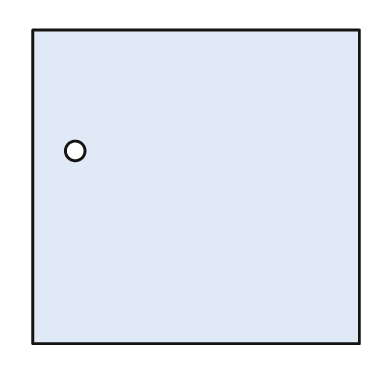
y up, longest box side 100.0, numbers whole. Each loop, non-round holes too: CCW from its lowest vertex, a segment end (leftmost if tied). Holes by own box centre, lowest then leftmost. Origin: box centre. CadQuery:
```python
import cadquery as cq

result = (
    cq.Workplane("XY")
    .moveTo(-50.0, -48.0)
    .lineTo(50.0, -48.0)
    .lineTo(50.0, 48.0)
    .lineTo(-50.0, 48.0)
    .close()
    .moveTo(-37.0, 11.0)
    .circle(3.0)
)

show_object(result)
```